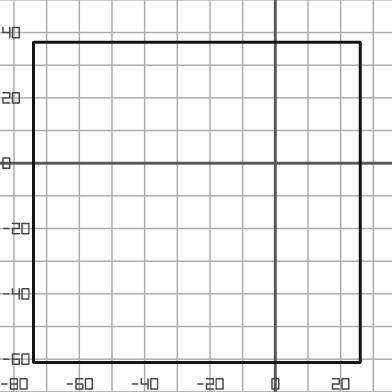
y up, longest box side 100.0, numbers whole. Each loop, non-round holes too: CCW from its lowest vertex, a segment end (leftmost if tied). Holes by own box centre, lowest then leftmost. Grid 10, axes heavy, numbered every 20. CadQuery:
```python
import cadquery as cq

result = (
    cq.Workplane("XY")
    .moveTo(-74.0, -61.0)
    .lineTo(26.0, -61.0)
    .lineTo(26.0, 37.0)
    .lineTo(-74.0, 37.0)
    .close()
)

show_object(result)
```